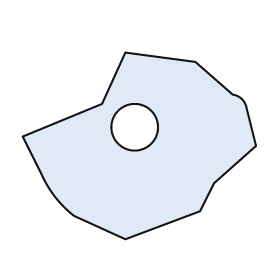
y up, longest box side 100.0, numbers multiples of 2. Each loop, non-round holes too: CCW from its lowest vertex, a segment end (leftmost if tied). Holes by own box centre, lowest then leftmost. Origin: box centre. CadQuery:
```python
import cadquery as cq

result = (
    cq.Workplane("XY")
    .moveTo(-6.0, -40.0)
    .lineTo(26.0, -28.0)
    .lineTo(32.0, -16.0)
    .lineTo(50.0, 0.0)
    .lineTo(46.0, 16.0)
    .threePointArc((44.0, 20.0), (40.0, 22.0))
    .lineTo(24.0, 36.0)
    .lineTo(-6.0, 40.0)
    .lineTo(-16.0, 18.0)
    .lineTo(-50.0, 4.0)
    .lineTo(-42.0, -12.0)
    .threePointArc((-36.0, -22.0), (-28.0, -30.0))
    .close()
    .moveTo(-2.0, 8.0)
    .circle(10.0)
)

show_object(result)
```